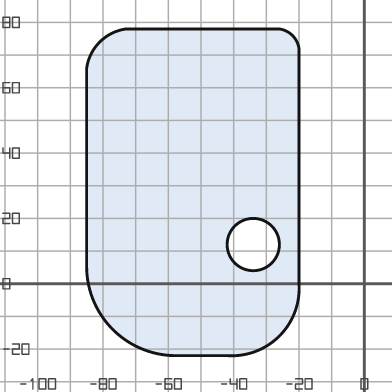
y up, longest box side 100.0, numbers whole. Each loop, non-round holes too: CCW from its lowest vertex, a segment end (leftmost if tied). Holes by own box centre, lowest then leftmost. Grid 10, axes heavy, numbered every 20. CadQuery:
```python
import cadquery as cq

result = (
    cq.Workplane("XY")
    .moveTo(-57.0, -22.0)
    .lineTo(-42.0, -22.0)
    .threePointArc((-26.0, -16.0), (-20.0, 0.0))
    .lineTo(-20.0, 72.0)
    .threePointArc((-22.0, 76.0), (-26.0, 78.0))
    .lineTo(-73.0, 78.0)
    .threePointArc((-81.0, 74.0), (-85.0, 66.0))
    .lineTo(-85.0, 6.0)
    .threePointArc((-77.0, -14.0), (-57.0, -22.0))
    .close()
    .moveTo(-34.0, 12.0)
    .circle(8.0)
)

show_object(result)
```